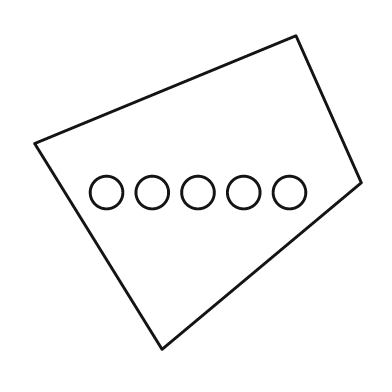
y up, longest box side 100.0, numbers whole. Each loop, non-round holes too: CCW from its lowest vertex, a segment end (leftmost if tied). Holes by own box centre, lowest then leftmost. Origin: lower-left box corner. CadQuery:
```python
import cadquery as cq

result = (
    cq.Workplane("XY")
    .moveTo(39.0, 0.0)
    .lineTo(100.0, 51.0)
    .lineTo(80.0, 96.0)
    .lineTo(0.0, 63.0)
    .close()
    .moveTo(22.0, 48.0)
    .circle(5.0)
    .moveTo(36.0, 48.0)
    .circle(5.0)
    .moveTo(50.0, 48.0)
    .circle(5.0)
    .moveTo(64.0, 48.0)
    .circle(5.0)
    .moveTo(78.0, 48.0)
    .circle(5.0)
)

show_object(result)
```